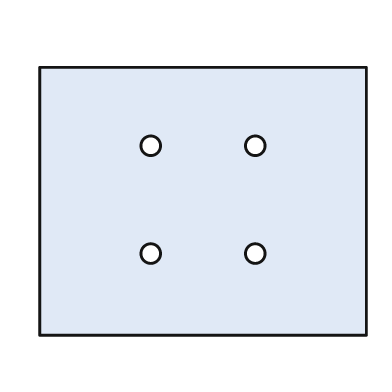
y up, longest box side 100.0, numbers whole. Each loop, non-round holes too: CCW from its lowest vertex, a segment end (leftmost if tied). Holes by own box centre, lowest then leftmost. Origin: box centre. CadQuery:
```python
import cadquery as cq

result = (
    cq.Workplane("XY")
    .moveTo(-50.0, -41.0)
    .lineTo(50.0, -41.0)
    .lineTo(50.0, 41.0)
    .lineTo(-50.0, 41.0)
    .close()
    .moveTo(-16.0, -16.0)
    .circle(3.0)
    .moveTo(16.0, -16.0)
    .circle(3.0)
    .moveTo(-16.0, 17.0)
    .circle(3.0)
    .moveTo(16.0, 17.0)
    .circle(3.0)
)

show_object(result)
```